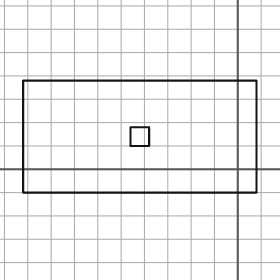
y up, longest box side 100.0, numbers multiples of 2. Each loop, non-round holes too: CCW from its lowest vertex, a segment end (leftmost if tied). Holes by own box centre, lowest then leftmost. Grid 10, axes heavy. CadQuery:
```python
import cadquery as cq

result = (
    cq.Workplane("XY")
    .moveTo(-92.0, -10.0)
    .lineTo(8.0, -10.0)
    .lineTo(8.0, 38.0)
    .lineTo(-92.0, 38.0)
    .close()
    .moveTo(-46.0, 10.0)
    .lineTo(-38.0, 10.0)
    .lineTo(-38.0, 18.0)
    .lineTo(-46.0, 18.0)
    .close()
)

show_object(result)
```